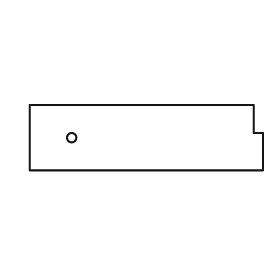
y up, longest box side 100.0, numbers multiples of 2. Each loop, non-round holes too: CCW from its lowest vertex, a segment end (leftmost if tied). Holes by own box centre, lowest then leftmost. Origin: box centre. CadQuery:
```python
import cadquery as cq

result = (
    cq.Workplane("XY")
    .moveTo(-50.0, -14.0)
    .lineTo(50.0, -14.0)
    .lineTo(50.0, 2.0)
    .lineTo(46.0, 2.0)
    .lineTo(46.0, 14.0)
    .lineTo(-50.0, 14.0)
    .close()
    .moveTo(-32.0, 0.0)
    .circle(2.0)
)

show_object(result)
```